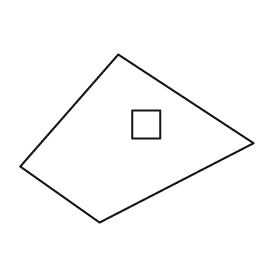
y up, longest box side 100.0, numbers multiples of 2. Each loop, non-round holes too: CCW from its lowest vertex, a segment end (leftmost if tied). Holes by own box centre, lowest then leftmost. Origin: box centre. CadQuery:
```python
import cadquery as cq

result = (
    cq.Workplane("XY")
    .moveTo(-16.0, -36.0)
    .lineTo(50.0, -2.0)
    .lineTo(-8.0, 36.0)
    .lineTo(-50.0, -12.0)
    .close()
    .moveTo(-2.0, 0.0)
    .lineTo(10.0, 0.0)
    .lineTo(10.0, 12.0)
    .lineTo(-2.0, 12.0)
    .close()
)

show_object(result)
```